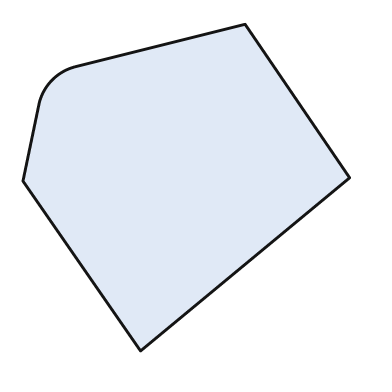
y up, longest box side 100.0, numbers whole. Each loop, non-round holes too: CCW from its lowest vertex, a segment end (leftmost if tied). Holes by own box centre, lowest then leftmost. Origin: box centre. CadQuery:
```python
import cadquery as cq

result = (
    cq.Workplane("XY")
    .moveTo(-14.0, -50.0)
    .lineTo(50.0, 3.0)
    .lineTo(18.0, 50.0)
    .lineTo(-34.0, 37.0)
    .threePointArc((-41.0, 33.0), (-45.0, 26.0))
    .lineTo(-50.0, 2.0)
    .close()
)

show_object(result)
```